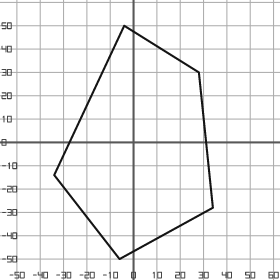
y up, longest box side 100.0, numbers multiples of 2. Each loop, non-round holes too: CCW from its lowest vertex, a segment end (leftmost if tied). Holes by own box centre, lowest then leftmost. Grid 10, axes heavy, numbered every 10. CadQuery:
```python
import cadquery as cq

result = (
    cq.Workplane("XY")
    .moveTo(-6.0, -50.0)
    .lineTo(34.0, -28.0)
    .lineTo(28.0, 30.0)
    .lineTo(-4.0, 50.0)
    .lineTo(-34.0, -14.0)
    .close()
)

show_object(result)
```